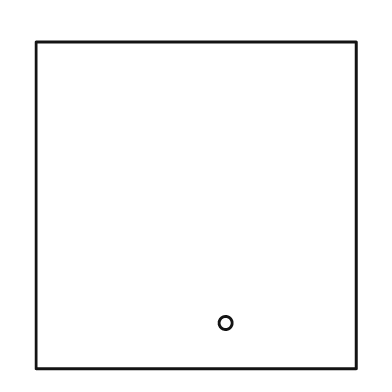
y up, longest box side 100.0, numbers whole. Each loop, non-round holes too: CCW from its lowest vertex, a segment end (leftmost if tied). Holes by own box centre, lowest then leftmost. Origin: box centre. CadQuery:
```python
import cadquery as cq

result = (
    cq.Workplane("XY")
    .moveTo(-49.0, -50.0)
    .lineTo(49.0, -50.0)
    .lineTo(49.0, 50.0)
    .lineTo(-49.0, 50.0)
    .close()
    .moveTo(9.0, -36.0)
    .circle(2.0)
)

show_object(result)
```